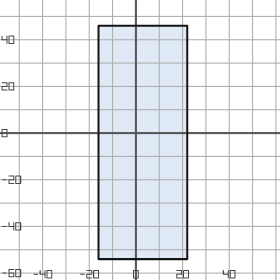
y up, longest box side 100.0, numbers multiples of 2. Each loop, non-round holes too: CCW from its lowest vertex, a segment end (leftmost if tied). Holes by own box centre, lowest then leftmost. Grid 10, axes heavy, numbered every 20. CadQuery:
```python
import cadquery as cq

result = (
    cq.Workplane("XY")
    .moveTo(-16.0, -54.0)
    .lineTo(22.0, -54.0)
    .lineTo(22.0, 46.0)
    .lineTo(-16.0, 46.0)
    .close()
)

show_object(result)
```